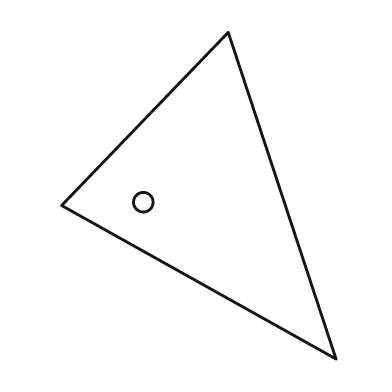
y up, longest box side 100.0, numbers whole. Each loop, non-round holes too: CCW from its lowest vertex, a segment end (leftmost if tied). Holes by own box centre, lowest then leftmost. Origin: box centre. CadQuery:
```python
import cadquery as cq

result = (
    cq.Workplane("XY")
    .moveTo(42.0, -50.0)
    .lineTo(9.0, 50.0)
    .lineTo(-42.0, -3.0)
    .close()
    .moveTo(-17.0, -2.0)
    .circle(3.0)
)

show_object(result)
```